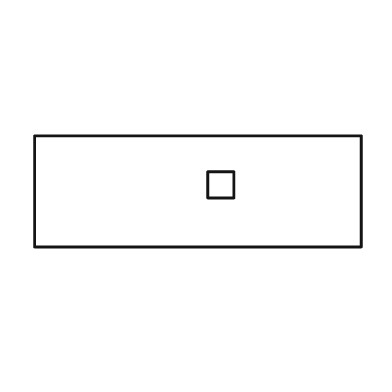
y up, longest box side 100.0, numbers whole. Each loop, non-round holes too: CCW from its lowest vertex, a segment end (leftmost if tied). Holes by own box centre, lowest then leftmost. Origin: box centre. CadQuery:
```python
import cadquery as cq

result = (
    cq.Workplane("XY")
    .moveTo(-50.0, -17.0)
    .lineTo(50.0, -17.0)
    .lineTo(50.0, 17.0)
    .lineTo(-50.0, 17.0)
    .close()
    .moveTo(3.0, -2.0)
    .lineTo(11.0, -2.0)
    .lineTo(11.0, 6.0)
    .lineTo(3.0, 6.0)
    .close()
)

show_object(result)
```